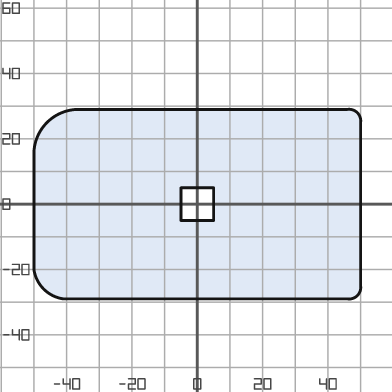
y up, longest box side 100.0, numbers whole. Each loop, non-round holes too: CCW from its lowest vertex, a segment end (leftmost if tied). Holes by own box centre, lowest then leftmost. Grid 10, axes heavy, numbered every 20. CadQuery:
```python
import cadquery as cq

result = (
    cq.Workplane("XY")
    .moveTo(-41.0, -29.0)
    .lineTo(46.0, -29.0)
    .threePointArc((49.0, -28.0), (50.0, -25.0))
    .lineTo(50.0, 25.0)
    .threePointArc((49.0, 28.0), (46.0, 29.0))
    .lineTo(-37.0, 29.0)
    .threePointArc((-46.0, 25.0), (-50.0, 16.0))
    .lineTo(-50.0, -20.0)
    .threePointArc((-47.0, -26.0), (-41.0, -29.0))
    .close()
    .moveTo(-5.0, -5.0)
    .lineTo(5.0, -5.0)
    .lineTo(5.0, 5.0)
    .lineTo(-5.0, 5.0)
    .close()
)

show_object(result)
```